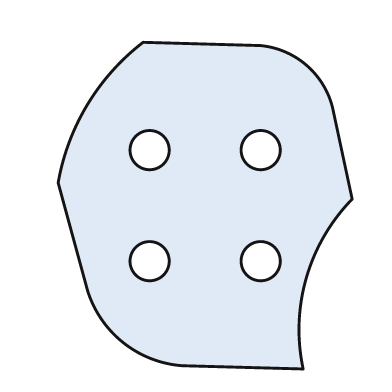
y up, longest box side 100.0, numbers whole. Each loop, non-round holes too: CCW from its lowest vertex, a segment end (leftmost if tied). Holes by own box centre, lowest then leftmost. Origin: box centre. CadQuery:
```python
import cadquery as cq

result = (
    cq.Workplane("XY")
    .moveTo(30.0, -50.0)
    .threePointArc((31.0, -22.0), (45.0, 2.0))
    .lineTo(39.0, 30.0)
    .threePointArc((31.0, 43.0), (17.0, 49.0))
    .lineTo(-19.0, 50.0)
    .threePointArc((-36.0, 31.0), (-45.0, 7.0))
    .lineTo(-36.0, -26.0)
    .threePointArc((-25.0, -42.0), (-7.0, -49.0))
    .close()
    .moveTo(-17.0, -17.0)
    .circle(6.0)
    .moveTo(17.0, -17.0)
    .circle(6.0)
    .moveTo(-17.0, 17.0)
    .circle(6.0)
    .moveTo(17.0, 17.0)
    .circle(6.0)
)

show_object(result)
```